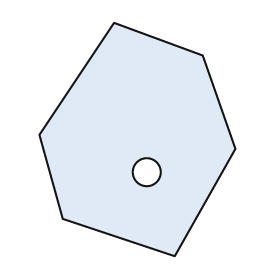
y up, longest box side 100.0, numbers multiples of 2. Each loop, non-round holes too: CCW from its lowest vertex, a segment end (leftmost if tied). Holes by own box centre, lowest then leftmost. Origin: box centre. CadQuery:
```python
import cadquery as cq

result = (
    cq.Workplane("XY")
    .moveTo(16.0, -50.0)
    .lineTo(42.0, -4.0)
    .lineTo(28.0, 36.0)
    .lineTo(-10.0, 50.0)
    .lineTo(-42.0, 2.0)
    .lineTo(-32.0, -34.0)
    .close()
    .moveTo(4.0, -14.0)
    .circle(6.0)
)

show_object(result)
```